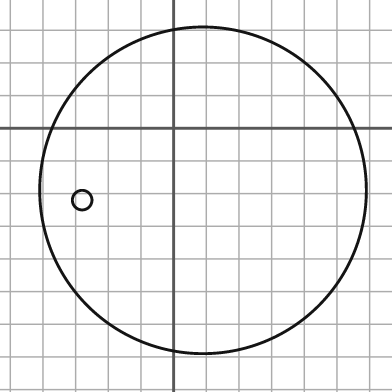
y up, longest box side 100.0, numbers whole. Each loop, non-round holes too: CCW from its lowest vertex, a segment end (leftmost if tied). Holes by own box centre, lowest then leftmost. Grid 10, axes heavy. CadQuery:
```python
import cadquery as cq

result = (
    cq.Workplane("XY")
    .moveTo(9.0, -19.0)
    .circle(50.0)
    .moveTo(-28.0, -22.0)
    .circle(3.0)
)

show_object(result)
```